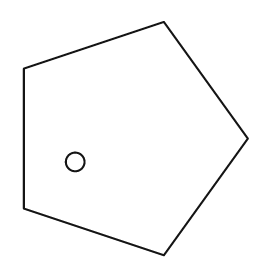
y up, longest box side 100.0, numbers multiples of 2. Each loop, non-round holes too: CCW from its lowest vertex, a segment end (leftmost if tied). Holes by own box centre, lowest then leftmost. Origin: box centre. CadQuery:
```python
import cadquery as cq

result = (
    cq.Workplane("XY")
    .moveTo(12.0, -50.0)
    .lineTo(48.0, 0.0)
    .lineTo(12.0, 50.0)
    .lineTo(-48.0, 30.0)
    .lineTo(-48.0, -30.0)
    .close()
    .moveTo(-26.0, -10.0)
    .circle(4.0)
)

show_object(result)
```